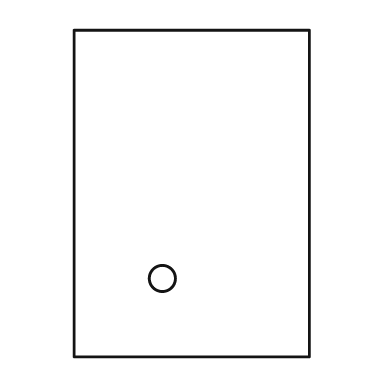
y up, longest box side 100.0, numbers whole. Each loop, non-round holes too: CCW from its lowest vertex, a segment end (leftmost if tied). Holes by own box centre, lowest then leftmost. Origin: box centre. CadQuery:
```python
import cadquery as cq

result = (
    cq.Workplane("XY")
    .moveTo(-36.0, -50.0)
    .lineTo(36.0, -50.0)
    .lineTo(36.0, 50.0)
    .lineTo(-36.0, 50.0)
    .close()
    .moveTo(-9.0, -26.0)
    .circle(4.0)
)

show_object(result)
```